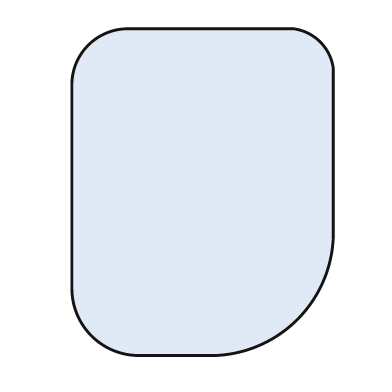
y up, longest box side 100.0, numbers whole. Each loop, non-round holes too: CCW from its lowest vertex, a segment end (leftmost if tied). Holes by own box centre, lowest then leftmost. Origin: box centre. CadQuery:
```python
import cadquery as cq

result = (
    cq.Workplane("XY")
    .moveTo(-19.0, -50.0)
    .lineTo(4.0, -50.0)
    .threePointArc((29.0, -39.0), (40.0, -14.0))
    .lineTo(40.0, 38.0)
    .threePointArc((36.0, 46.0), (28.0, 50.0))
    .lineTo(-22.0, 50.0)
    .threePointArc((-35.0, 45.0), (-40.0, 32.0))
    .lineTo(-40.0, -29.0)
    .threePointArc((-34.0, -44.0), (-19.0, -50.0))
    .close()
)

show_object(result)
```